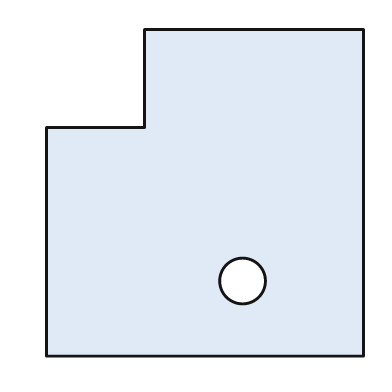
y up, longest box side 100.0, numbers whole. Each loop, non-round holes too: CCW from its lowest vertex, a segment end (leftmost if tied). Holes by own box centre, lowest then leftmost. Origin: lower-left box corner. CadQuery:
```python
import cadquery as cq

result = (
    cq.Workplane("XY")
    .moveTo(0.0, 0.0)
    .lineTo(97.0, 0.0)
    .lineTo(97.0, 100.0)
    .lineTo(30.0, 100.0)
    .lineTo(30.0, 70.0)
    .lineTo(0.0, 70.0)
    .close()
    .moveTo(60.0, 23.0)
    .circle(7.0)
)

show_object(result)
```